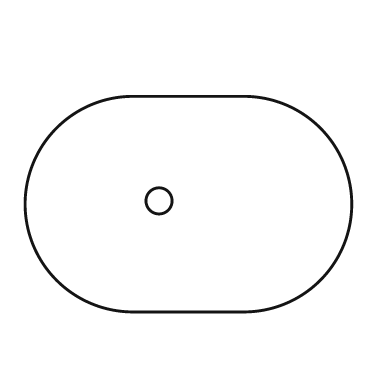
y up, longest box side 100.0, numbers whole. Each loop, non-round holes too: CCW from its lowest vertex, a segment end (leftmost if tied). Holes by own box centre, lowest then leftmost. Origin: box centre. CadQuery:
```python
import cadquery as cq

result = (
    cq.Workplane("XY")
    .moveTo(-17.0, -33.0)
    .lineTo(17.0, -33.0)
    .threePointArc((50.0, 0.0), (17.0, 33.0))
    .lineTo(-17.0, 33.0)
    .threePointArc((-50.0, 0.0), (-17.0, -33.0))
    .close()
    .moveTo(-9.0, 1.0)
    .circle(4.0)
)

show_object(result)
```